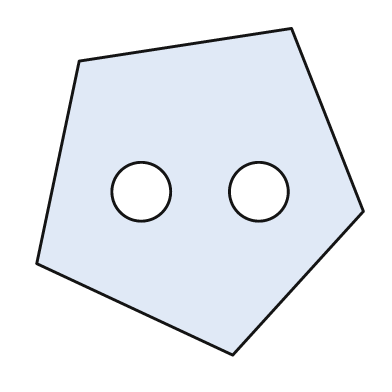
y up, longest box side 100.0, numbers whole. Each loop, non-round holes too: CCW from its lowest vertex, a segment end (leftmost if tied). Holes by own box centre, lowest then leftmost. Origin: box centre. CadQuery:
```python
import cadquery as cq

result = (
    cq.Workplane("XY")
    .moveTo(10.0, -50.0)
    .lineTo(50.0, -6.0)
    .lineTo(28.0, 50.0)
    .lineTo(-37.0, 40.0)
    .lineTo(-50.0, -22.0)
    .close()
    .moveTo(-18.0, 0.0)
    .circle(9.0)
    .moveTo(18.0, 0.0)
    .circle(9.0)
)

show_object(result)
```